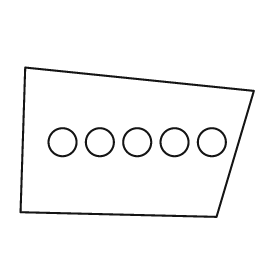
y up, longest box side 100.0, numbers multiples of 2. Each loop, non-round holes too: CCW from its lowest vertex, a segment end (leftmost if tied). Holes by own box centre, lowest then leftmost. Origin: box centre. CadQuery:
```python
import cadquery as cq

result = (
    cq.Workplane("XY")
    .moveTo(34.0, -32.0)
    .lineTo(50.0, 22.0)
    .lineTo(-48.0, 32.0)
    .lineTo(-50.0, -30.0)
    .close()
    .moveTo(-32.0, 0.0)
    .circle(6.0)
    .moveTo(-16.0, 0.0)
    .circle(6.0)
    .moveTo(0.0, 0.0)
    .circle(6.0)
    .moveTo(16.0, 0.0)
    .circle(6.0)
    .moveTo(32.0, 0.0)
    .circle(6.0)
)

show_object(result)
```